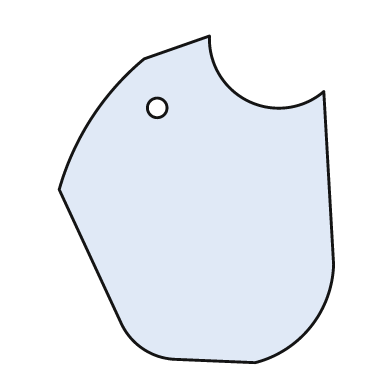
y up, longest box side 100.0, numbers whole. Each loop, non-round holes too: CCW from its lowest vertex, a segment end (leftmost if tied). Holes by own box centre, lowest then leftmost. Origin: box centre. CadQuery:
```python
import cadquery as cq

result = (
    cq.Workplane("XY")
    .moveTo(18.0, -50.0)
    .threePointArc((35.0, -39.0), (42.0, -20.0))
    .lineTo(39.0, 33.0)
    .threePointArc((16.0, 30.0), (4.0, 50.0))
    .lineTo(-16.0, 43.0)
    .threePointArc((-32.0, 25.0), (-42.0, 3.0))
    .lineTo(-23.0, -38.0)
    .threePointArc((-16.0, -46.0), (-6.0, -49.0))
    .close()
    .moveTo(-12.0, 28.0)
    .circle(3.0)
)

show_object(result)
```